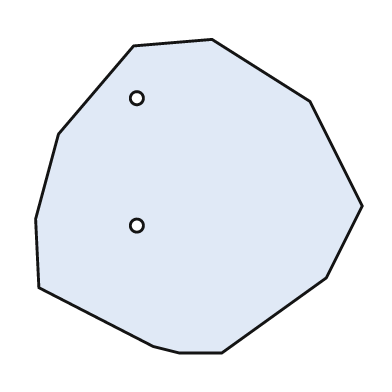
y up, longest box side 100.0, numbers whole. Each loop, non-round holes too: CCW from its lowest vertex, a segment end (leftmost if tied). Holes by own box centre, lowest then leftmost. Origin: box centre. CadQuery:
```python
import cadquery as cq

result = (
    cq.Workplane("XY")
    .moveTo(-6.0, -48.0)
    .lineTo(7.0, -48.0)
    .lineTo(39.0, -25.0)
    .lineTo(50.0, -3.0)
    .lineTo(34.0, 29.0)
    .lineTo(4.0, 48.0)
    .lineTo(-20.0, 46.0)
    .lineTo(-43.0, 19.0)
    .lineTo(-50.0, -7.0)
    .lineTo(-49.0, -28.0)
    .lineTo(-14.0, -46.0)
    .close()
    .moveTo(-19.0, -9.0)
    .circle(2.0)
    .moveTo(-19.0, 30.0)
    .circle(2.0)
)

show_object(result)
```